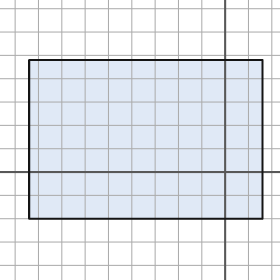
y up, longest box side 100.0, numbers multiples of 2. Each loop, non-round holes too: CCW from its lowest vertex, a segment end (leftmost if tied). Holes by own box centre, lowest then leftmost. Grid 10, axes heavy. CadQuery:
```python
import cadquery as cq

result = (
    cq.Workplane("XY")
    .moveTo(-84.0, -20.0)
    .lineTo(16.0, -20.0)
    .lineTo(16.0, 48.0)
    .lineTo(-84.0, 48.0)
    .close()
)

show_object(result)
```